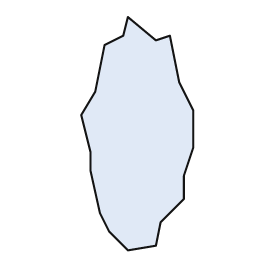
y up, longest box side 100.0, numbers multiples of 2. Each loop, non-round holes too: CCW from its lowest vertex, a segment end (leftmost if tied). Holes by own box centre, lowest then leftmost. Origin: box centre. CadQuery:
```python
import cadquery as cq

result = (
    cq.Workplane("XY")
    .moveTo(-4.0, -50.0)
    .lineTo(8.0, -48.0)
    .lineTo(10.0, -38.0)
    .lineTo(20.0, -28.0)
    .lineTo(20.0, -18.0)
    .lineTo(24.0, -6.0)
    .lineTo(24.0, 10.0)
    .lineTo(18.0, 22.0)
    .lineTo(14.0, 42.0)
    .lineTo(8.0, 40.0)
    .lineTo(-4.0, 50.0)
    .lineTo(-6.0, 42.0)
    .lineTo(-14.0, 38.0)
    .lineTo(-18.0, 18.0)
    .lineTo(-24.0, 8.0)
    .lineTo(-20.0, -8.0)
    .lineTo(-20.0, -16.0)
    .lineTo(-16.0, -34.0)
    .lineTo(-12.0, -42.0)
    .close()
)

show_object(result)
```